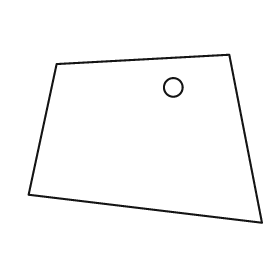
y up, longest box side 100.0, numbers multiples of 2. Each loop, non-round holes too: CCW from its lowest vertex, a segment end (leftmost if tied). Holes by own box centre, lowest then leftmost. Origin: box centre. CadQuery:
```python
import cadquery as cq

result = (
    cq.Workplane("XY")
    .moveTo(50.0, -36.0)
    .lineTo(36.0, 36.0)
    .lineTo(-38.0, 32.0)
    .lineTo(-50.0, -24.0)
    .close()
    .moveTo(12.0, 22.0)
    .circle(4.0)
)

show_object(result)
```